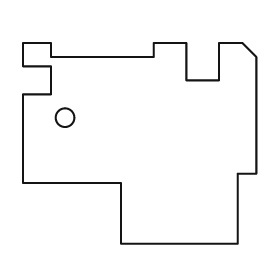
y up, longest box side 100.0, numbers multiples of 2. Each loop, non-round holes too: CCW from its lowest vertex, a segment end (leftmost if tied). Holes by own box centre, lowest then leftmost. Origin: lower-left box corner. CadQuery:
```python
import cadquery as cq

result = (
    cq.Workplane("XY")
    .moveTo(42.0, 0.0)
    .lineTo(92.0, 0.0)
    .lineTo(92.0, 30.0)
    .lineTo(100.0, 30.0)
    .lineTo(100.0, 80.0)
    .lineTo(94.0, 86.0)
    .lineTo(84.0, 86.0)
    .lineTo(84.0, 70.0)
    .lineTo(70.0, 70.0)
    .lineTo(70.0, 86.0)
    .lineTo(56.0, 86.0)
    .lineTo(56.0, 80.0)
    .lineTo(12.0, 80.0)
    .lineTo(12.0, 86.0)
    .lineTo(0.0, 86.0)
    .lineTo(0.0, 76.0)
    .lineTo(12.0, 76.0)
    .lineTo(12.0, 64.0)
    .lineTo(0.0, 64.0)
    .lineTo(0.0, 26.0)
    .lineTo(42.0, 26.0)
    .close()
    .moveTo(18.0, 54.0)
    .circle(4.0)
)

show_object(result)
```